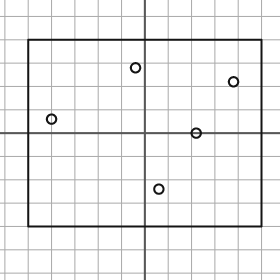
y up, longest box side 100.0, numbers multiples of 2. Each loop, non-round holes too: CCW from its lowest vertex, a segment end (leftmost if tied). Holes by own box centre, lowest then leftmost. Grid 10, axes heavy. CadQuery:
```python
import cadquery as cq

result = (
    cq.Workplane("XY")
    .moveTo(-50.0, -40.0)
    .lineTo(50.0, -40.0)
    .lineTo(50.0, 40.0)
    .lineTo(-50.0, 40.0)
    .close()
    .moveTo(6.0, -24.0)
    .circle(2.0)
    .moveTo(22.0, 0.0)
    .circle(2.0)
    .moveTo(-40.0, 6.0)
    .circle(2.0)
    .moveTo(38.0, 22.0)
    .circle(2.0)
    .moveTo(-4.0, 28.0)
    .circle(2.0)
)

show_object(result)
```